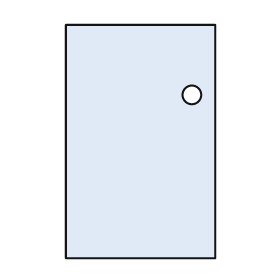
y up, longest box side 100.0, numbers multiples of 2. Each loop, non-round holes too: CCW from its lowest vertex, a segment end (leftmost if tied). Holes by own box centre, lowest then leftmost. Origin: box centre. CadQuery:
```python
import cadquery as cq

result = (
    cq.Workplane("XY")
    .moveTo(-32.0, -50.0)
    .lineTo(32.0, -50.0)
    .lineTo(32.0, 50.0)
    .lineTo(-32.0, 50.0)
    .close()
    .moveTo(22.0, 20.0)
    .circle(4.0)
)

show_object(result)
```